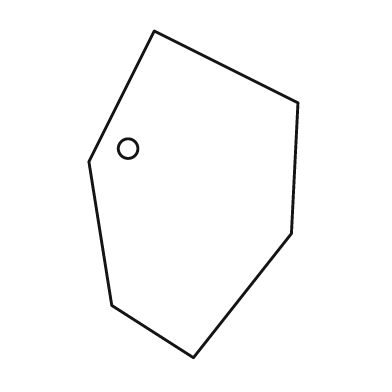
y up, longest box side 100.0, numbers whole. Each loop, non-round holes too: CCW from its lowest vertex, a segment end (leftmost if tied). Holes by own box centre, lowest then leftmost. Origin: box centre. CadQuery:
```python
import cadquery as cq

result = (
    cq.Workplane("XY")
    .moveTo(0.0, -50.0)
    .lineTo(30.0, -12.0)
    .lineTo(32.0, 28.0)
    .lineTo(-12.0, 50.0)
    .lineTo(-32.0, 10.0)
    .lineTo(-25.0, -34.0)
    .close()
    .moveTo(-20.0, 14.0)
    .circle(3.0)
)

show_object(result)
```